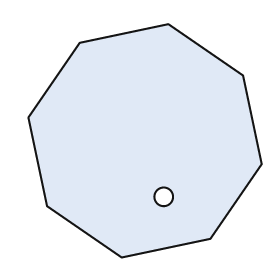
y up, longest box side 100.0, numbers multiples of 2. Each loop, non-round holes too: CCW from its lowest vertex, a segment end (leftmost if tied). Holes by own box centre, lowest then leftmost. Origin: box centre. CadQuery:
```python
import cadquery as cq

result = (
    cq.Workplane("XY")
    .moveTo(-10.0, -50.0)
    .lineTo(28.0, -42.0)
    .lineTo(50.0, -10.0)
    .lineTo(42.0, 28.0)
    .lineTo(10.0, 50.0)
    .lineTo(-28.0, 42.0)
    .lineTo(-50.0, 10.0)
    .lineTo(-42.0, -28.0)
    .close()
    .moveTo(8.0, -24.0)
    .circle(4.0)
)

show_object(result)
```